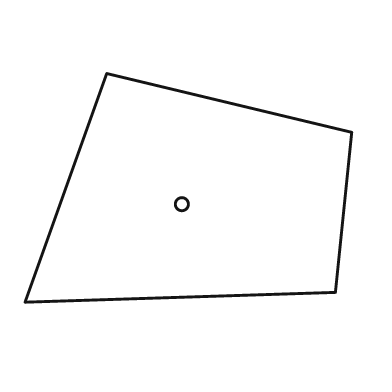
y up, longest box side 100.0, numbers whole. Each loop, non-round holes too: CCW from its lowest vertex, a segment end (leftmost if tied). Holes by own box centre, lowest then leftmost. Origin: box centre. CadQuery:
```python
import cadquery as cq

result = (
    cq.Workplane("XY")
    .moveTo(-50.0, -35.0)
    .lineTo(45.0, -32.0)
    .lineTo(50.0, 17.0)
    .lineTo(-25.0, 35.0)
    .close()
    .moveTo(-2.0, -5.0)
    .circle(2.0)
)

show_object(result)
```